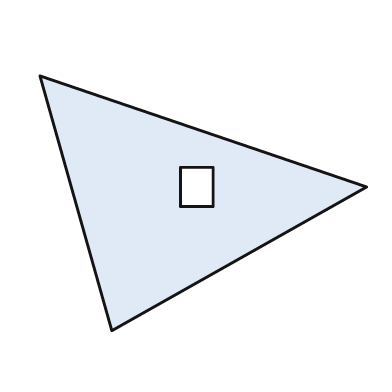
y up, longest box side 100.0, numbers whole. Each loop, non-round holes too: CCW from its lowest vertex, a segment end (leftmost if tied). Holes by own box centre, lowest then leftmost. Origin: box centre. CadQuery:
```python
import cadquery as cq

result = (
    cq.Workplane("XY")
    .moveTo(-28.0, -39.0)
    .lineTo(50.0, 5.0)
    .lineTo(-50.0, 39.0)
    .close()
    .moveTo(-7.0, -1.0)
    .lineTo(3.0, -1.0)
    .lineTo(3.0, 11.0)
    .lineTo(-7.0, 11.0)
    .close()
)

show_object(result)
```